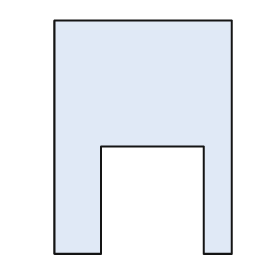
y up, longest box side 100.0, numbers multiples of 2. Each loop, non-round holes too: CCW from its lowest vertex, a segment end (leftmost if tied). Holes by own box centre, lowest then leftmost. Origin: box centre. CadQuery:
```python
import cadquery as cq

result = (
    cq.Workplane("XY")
    .moveTo(-38.0, -50.0)
    .lineTo(-18.0, -50.0)
    .lineTo(-18.0, -4.0)
    .lineTo(26.0, -4.0)
    .lineTo(26.0, -50.0)
    .lineTo(38.0, -50.0)
    .lineTo(38.0, 50.0)
    .lineTo(-38.0, 50.0)
    .close()
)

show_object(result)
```